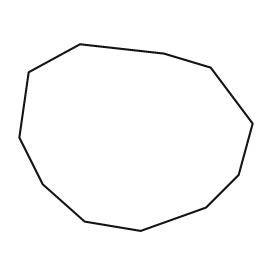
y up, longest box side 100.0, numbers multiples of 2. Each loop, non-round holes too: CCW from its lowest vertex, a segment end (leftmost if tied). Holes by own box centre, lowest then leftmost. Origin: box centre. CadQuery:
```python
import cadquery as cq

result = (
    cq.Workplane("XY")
    .moveTo(2.0, -40.0)
    .lineTo(30.0, -30.0)
    .lineTo(44.0, -16.0)
    .lineTo(50.0, 6.0)
    .lineTo(32.0, 30.0)
    .lineTo(12.0, 36.0)
    .lineTo(-24.0, 40.0)
    .lineTo(-46.0, 28.0)
    .lineTo(-50.0, 0.0)
    .lineTo(-40.0, -20.0)
    .lineTo(-22.0, -36.0)
    .close()
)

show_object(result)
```